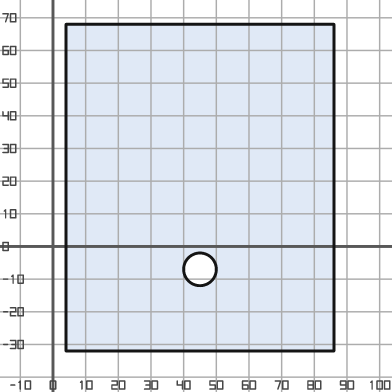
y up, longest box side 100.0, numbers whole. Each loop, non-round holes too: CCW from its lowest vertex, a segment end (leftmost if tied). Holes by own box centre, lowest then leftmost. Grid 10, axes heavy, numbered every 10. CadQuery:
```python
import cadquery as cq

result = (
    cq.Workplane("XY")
    .moveTo(4.0, -32.0)
    .lineTo(86.0, -32.0)
    .lineTo(86.0, 68.0)
    .lineTo(4.0, 68.0)
    .close()
    .moveTo(45.0, -7.0)
    .circle(5.0)
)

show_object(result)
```